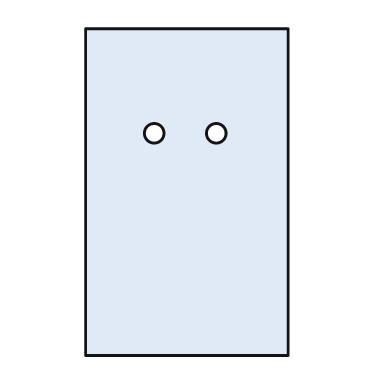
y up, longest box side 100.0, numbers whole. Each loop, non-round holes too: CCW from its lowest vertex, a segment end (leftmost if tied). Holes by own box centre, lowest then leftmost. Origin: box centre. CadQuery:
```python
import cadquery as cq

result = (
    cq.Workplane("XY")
    .moveTo(-31.0, -50.0)
    .lineTo(31.0, -50.0)
    .lineTo(31.0, 50.0)
    .lineTo(-31.0, 50.0)
    .close()
    .moveTo(-10.0, 18.0)
    .circle(3.0)
    .moveTo(9.0, 18.0)
    .circle(3.0)
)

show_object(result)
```